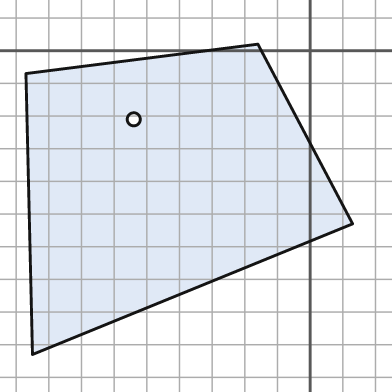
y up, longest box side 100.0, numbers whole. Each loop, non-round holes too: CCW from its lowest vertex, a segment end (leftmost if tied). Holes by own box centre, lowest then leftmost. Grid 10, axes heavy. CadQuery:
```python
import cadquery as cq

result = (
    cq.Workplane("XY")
    .moveTo(-85.0, -93.0)
    .lineTo(13.0, -53.0)
    .lineTo(-16.0, 2.0)
    .lineTo(-87.0, -7.0)
    .close()
    .moveTo(-54.0, -21.0)
    .circle(2.0)
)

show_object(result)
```